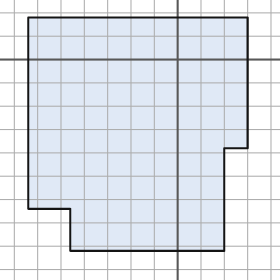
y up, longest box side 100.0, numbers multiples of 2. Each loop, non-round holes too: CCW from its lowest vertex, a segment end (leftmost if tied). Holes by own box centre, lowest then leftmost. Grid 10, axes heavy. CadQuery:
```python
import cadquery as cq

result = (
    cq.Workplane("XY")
    .moveTo(-46.0, -82.0)
    .lineTo(20.0, -82.0)
    .lineTo(20.0, -38.0)
    .lineTo(30.0, -38.0)
    .lineTo(30.0, 18.0)
    .lineTo(-64.0, 18.0)
    .lineTo(-64.0, -64.0)
    .lineTo(-46.0, -64.0)
    .close()
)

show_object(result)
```